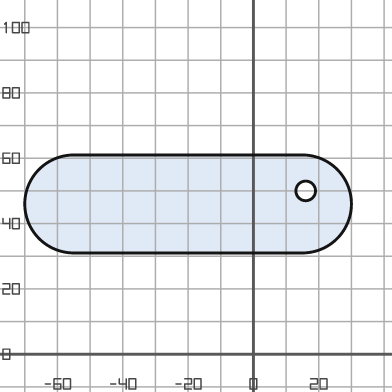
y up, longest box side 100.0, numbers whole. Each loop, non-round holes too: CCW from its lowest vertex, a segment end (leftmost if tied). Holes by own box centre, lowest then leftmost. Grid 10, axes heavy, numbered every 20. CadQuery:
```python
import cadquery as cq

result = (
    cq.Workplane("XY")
    .moveTo(-55.0, 31.0)
    .lineTo(15.0, 31.0)
    .threePointArc((30.0, 46.0), (15.0, 61.0))
    .lineTo(-55.0, 61.0)
    .threePointArc((-70.0, 46.0), (-55.0, 31.0))
    .close()
    .moveTo(16.0, 50.0)
    .circle(3.0)
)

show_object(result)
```